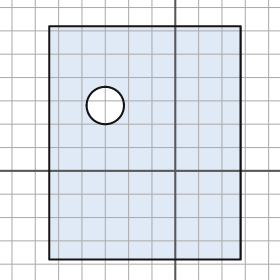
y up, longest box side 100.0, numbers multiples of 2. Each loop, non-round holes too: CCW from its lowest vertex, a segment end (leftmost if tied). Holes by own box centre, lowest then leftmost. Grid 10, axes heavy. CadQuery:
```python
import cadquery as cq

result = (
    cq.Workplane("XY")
    .moveTo(-54.0, -38.0)
    .lineTo(28.0, -38.0)
    .lineTo(28.0, 62.0)
    .lineTo(-54.0, 62.0)
    .close()
    .moveTo(-30.0, 28.0)
    .circle(8.0)
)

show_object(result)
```